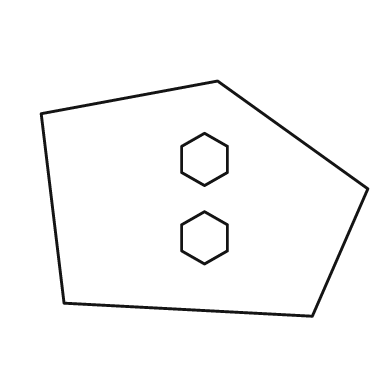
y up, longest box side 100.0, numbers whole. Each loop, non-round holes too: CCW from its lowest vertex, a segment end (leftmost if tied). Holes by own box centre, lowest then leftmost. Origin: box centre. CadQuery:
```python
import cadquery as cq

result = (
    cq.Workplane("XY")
    .moveTo(33.0, -36.0)
    .lineTo(50.0, 3.0)
    .lineTo(4.0, 36.0)
    .lineTo(-50.0, 26.0)
    .lineTo(-43.0, -32.0)
    .close()
    .moveTo(0.0, -20.0)
    .lineTo(7.0, -16.0)
    .lineTo(7.0, -8.0)
    .lineTo(0.0, -4.0)
    .lineTo(-7.0, -8.0)
    .lineTo(-7.0, -16.0)
    .close()
    .moveTo(0.0, 4.0)
    .lineTo(7.0, 8.0)
    .lineTo(7.0, 16.0)
    .lineTo(0.0, 20.0)
    .lineTo(-7.0, 16.0)
    .lineTo(-7.0, 8.0)
    .close()
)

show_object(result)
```